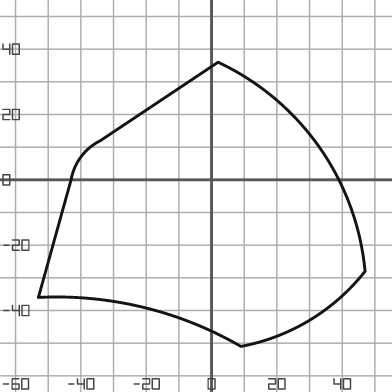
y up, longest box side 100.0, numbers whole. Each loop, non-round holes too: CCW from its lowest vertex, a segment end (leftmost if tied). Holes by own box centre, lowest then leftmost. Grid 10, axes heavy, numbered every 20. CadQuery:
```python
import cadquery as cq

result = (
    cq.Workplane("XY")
    .moveTo(9.0, -51.0)
    .threePointArc((30.0, -43.0), (47.0, -28.0))
    .threePointArc((33.0, 10.0), (2.0, 36.0))
    .lineTo(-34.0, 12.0)
    .threePointArc((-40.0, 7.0), (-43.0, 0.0))
    .lineTo(-53.0, -36.0)
    .threePointArc((-21.0, -39.0), (9.0, -51.0))
    .close()
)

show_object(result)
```